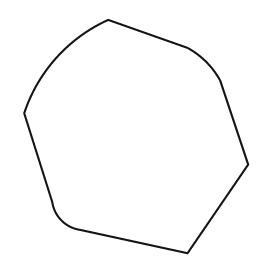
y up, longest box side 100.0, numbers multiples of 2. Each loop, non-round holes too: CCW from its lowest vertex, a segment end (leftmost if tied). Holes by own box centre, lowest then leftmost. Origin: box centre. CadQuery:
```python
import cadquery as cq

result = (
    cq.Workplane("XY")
    .moveTo(22.0, -50.0)
    .lineTo(48.0, -12.0)
    .lineTo(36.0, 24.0)
    .threePointArc((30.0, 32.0), (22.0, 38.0))
    .lineTo(-12.0, 50.0)
    .threePointArc((-34.0, 34.0), (-48.0, 10.0))
    .lineTo(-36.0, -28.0)
    .threePointArc((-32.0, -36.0), (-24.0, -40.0))
    .close()
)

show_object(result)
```